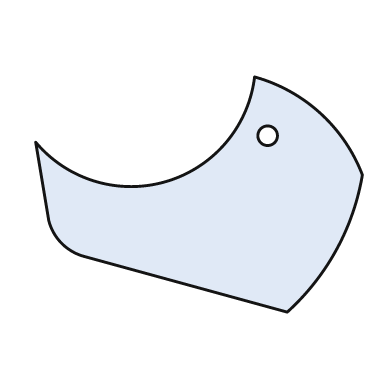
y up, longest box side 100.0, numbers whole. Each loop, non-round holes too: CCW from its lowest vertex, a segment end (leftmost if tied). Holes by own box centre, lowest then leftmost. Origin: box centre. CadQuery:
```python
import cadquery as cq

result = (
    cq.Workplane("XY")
    .moveTo(27.0, -36.0)
    .threePointArc((42.0, -17.0), (50.0, 6.0))
    .threePointArc((37.0, 25.0), (17.0, 36.0))
    .threePointArc((-10.0, 4.0), (-50.0, 16.0))
    .lineTo(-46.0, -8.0)
    .threePointArc((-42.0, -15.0), (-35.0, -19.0))
    .close()
    .moveTo(21.0, 18.0)
    .circle(3.0)
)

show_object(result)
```